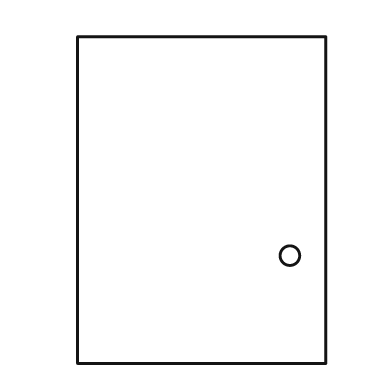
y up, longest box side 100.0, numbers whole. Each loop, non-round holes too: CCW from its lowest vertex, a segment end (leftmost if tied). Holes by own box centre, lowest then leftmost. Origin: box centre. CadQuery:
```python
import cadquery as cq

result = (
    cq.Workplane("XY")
    .moveTo(-38.0, -50.0)
    .lineTo(38.0, -50.0)
    .lineTo(38.0, 50.0)
    .lineTo(-38.0, 50.0)
    .close()
    .moveTo(27.0, -17.0)
    .circle(3.0)
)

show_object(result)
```